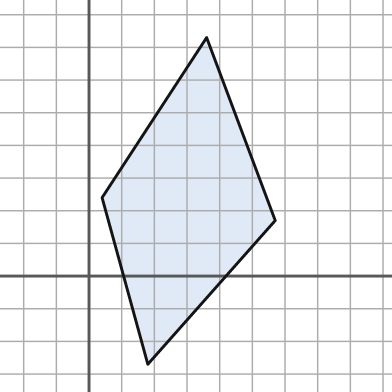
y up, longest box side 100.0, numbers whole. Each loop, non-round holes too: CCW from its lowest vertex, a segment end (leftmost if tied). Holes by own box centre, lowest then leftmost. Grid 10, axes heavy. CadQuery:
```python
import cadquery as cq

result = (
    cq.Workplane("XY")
    .moveTo(18.0, -27.0)
    .lineTo(57.0, 17.0)
    .lineTo(36.0, 73.0)
    .lineTo(4.0, 24.0)
    .close()
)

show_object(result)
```